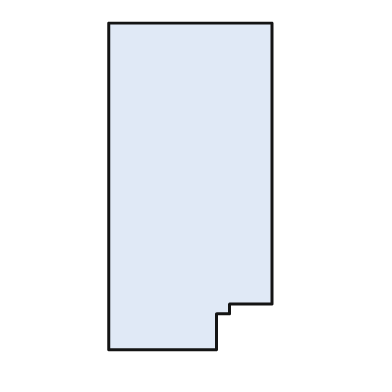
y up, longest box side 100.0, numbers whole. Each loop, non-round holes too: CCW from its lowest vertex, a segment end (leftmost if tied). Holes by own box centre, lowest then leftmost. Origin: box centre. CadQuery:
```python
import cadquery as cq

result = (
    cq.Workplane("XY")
    .moveTo(-25.0, -50.0)
    .lineTo(8.0, -50.0)
    .lineTo(8.0, -39.0)
    .lineTo(12.0, -39.0)
    .lineTo(12.0, -36.0)
    .lineTo(25.0, -36.0)
    .lineTo(25.0, 50.0)
    .lineTo(-25.0, 50.0)
    .close()
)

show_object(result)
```